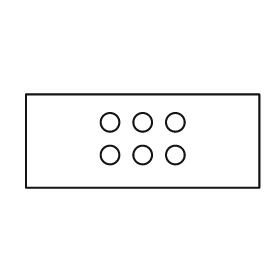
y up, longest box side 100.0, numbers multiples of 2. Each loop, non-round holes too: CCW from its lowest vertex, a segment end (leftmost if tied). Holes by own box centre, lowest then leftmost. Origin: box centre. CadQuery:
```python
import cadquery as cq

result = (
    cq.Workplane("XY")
    .moveTo(-50.0, -20.0)
    .lineTo(50.0, -20.0)
    .lineTo(50.0, 20.0)
    .lineTo(-50.0, 20.0)
    .close()
    .moveTo(-14.0, -6.0)
    .circle(4.0)
    .moveTo(0.0, -6.0)
    .circle(4.0)
    .moveTo(14.0, -6.0)
    .circle(4.0)
    .moveTo(-14.0, 8.0)
    .circle(4.0)
    .moveTo(0.0, 8.0)
    .circle(4.0)
    .moveTo(14.0, 8.0)
    .circle(4.0)
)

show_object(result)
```